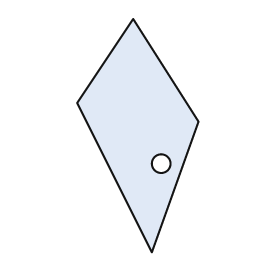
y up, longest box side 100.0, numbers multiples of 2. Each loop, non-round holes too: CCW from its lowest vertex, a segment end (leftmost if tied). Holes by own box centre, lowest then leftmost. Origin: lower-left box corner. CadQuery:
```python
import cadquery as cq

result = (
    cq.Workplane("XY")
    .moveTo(32.0, 0.0)
    .lineTo(52.0, 56.0)
    .lineTo(24.0, 100.0)
    .lineTo(0.0, 64.0)
    .close()
    .moveTo(36.0, 38.0)
    .circle(4.0)
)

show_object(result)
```